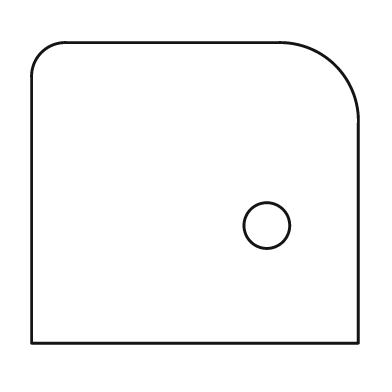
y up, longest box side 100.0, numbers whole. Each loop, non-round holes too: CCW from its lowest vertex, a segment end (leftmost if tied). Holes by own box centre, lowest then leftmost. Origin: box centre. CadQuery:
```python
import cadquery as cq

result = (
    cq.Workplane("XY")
    .moveTo(-50.0, -46.0)
    .lineTo(50.0, -46.0)
    .lineTo(50.0, 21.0)
    .threePointArc((43.0, 39.0), (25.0, 46.0))
    .lineTo(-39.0, 46.0)
    .threePointArc((-47.0, 43.0), (-50.0, 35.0))
    .close()
    .moveTo(22.0, -10.0)
    .circle(7.0)
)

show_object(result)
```